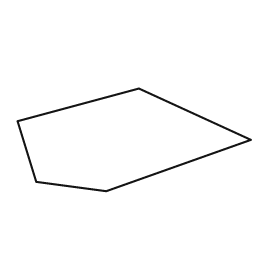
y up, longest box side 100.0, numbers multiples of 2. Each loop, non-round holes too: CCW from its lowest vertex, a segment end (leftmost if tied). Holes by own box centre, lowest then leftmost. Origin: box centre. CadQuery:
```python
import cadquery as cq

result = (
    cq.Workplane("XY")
    .moveTo(-12.0, -22.0)
    .lineTo(50.0, 0.0)
    .lineTo(2.0, 22.0)
    .lineTo(-50.0, 8.0)
    .lineTo(-42.0, -18.0)
    .close()
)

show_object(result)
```